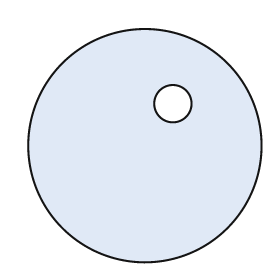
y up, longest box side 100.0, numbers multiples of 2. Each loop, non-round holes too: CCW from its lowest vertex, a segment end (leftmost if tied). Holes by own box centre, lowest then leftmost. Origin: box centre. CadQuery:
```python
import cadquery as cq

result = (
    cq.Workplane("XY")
    .moveTo(0.0, 0.0)
    .circle(50.0)
    .moveTo(12.0, 18.0)
    .circle(8.0)
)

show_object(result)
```